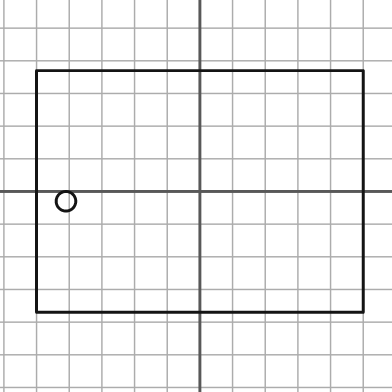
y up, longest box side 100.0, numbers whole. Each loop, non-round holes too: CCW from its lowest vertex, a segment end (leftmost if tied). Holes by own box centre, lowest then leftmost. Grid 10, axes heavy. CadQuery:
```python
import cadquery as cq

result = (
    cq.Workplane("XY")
    .moveTo(-50.0, -37.0)
    .lineTo(50.0, -37.0)
    .lineTo(50.0, 37.0)
    .lineTo(-50.0, 37.0)
    .close()
    .moveTo(-41.0, -3.0)
    .circle(3.0)
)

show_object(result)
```